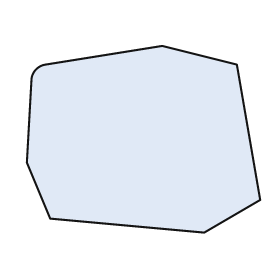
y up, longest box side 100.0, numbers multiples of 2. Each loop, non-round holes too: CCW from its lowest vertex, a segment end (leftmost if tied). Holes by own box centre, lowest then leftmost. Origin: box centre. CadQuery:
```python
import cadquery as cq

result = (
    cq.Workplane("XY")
    .moveTo(26.0, -40.0)
    .lineTo(50.0, -26.0)
    .lineTo(40.0, 32.0)
    .lineTo(8.0, 40.0)
    .lineTo(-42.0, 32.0)
    .threePointArc((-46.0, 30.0), (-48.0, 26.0))
    .lineTo(-50.0, -10.0)
    .lineTo(-40.0, -34.0)
    .close()
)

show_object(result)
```